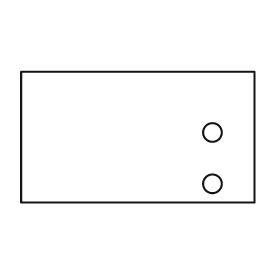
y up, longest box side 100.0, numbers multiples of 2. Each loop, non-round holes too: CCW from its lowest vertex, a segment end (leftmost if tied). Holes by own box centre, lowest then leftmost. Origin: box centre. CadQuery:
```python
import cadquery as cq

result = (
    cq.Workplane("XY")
    .moveTo(-50.0, -28.0)
    .lineTo(50.0, -28.0)
    .lineTo(50.0, 28.0)
    .lineTo(-50.0, 28.0)
    .close()
    .moveTo(32.0, -20.0)
    .circle(4.0)
    .moveTo(32.0, 2.0)
    .circle(4.0)
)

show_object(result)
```